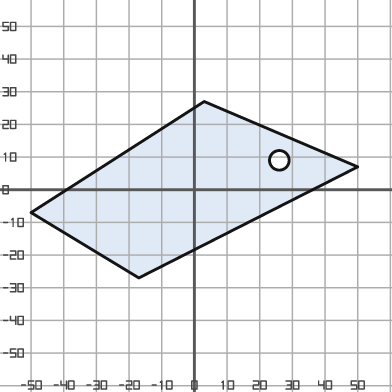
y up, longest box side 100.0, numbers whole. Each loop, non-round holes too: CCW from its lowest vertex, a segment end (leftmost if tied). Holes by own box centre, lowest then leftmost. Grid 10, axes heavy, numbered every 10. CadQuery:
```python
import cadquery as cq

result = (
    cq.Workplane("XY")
    .moveTo(-17.0, -27.0)
    .lineTo(50.0, 7.0)
    .lineTo(3.0, 27.0)
    .lineTo(-50.0, -7.0)
    .close()
    .moveTo(26.0, 9.0)
    .circle(3.0)
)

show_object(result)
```